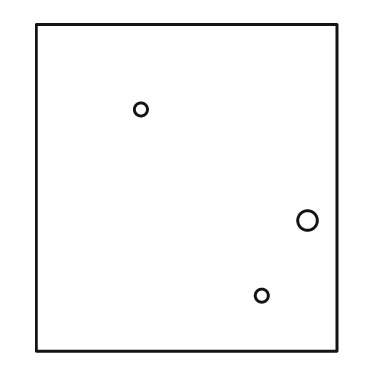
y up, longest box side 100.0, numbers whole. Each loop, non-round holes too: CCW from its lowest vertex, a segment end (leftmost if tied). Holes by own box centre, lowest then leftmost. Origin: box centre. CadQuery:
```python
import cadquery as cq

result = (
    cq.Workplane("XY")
    .moveTo(-46.0, -50.0)
    .lineTo(46.0, -50.0)
    .lineTo(46.0, 50.0)
    .lineTo(-46.0, 50.0)
    .close()
    .moveTo(23.0, -33.0)
    .circle(2.0)
    .moveTo(37.0, -10.0)
    .circle(3.0)
    .moveTo(-14.0, 24.0)
    .circle(2.0)
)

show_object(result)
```